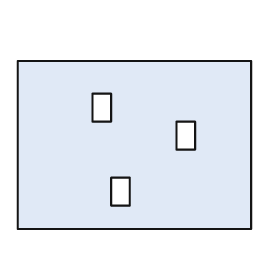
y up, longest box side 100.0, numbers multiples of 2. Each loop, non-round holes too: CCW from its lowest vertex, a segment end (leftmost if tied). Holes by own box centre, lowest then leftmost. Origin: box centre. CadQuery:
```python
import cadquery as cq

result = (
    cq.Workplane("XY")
    .moveTo(-50.0, -36.0)
    .lineTo(50.0, -36.0)
    .lineTo(50.0, 36.0)
    .lineTo(-50.0, 36.0)
    .close()
    .moveTo(-10.0, -26.0)
    .lineTo(-2.0, -26.0)
    .lineTo(-2.0, -14.0)
    .lineTo(-10.0, -14.0)
    .close()
    .moveTo(18.0, -2.0)
    .lineTo(26.0, -2.0)
    .lineTo(26.0, 10.0)
    .lineTo(18.0, 10.0)
    .close()
    .moveTo(-18.0, 10.0)
    .lineTo(-10.0, 10.0)
    .lineTo(-10.0, 22.0)
    .lineTo(-18.0, 22.0)
    .close()
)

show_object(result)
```